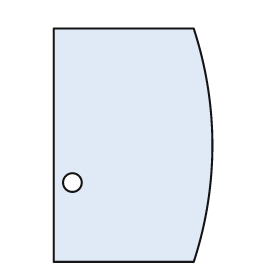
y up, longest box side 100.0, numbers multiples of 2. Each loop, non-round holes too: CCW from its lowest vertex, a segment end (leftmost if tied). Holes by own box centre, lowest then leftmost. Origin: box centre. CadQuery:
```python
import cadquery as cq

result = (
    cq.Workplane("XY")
    .moveTo(-34.0, -50.0)
    .lineTo(26.0, -50.0)
    .threePointArc((34.0, 0.0), (26.0, 50.0))
    .lineTo(-34.0, 50.0)
    .close()
    .moveTo(-26.0, -16.0)
    .circle(4.0)
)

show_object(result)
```